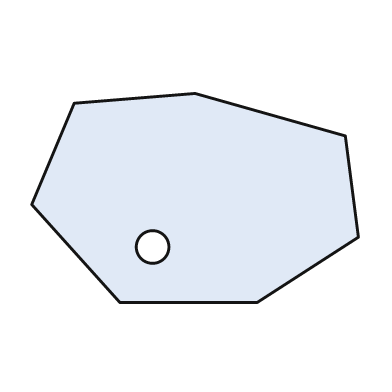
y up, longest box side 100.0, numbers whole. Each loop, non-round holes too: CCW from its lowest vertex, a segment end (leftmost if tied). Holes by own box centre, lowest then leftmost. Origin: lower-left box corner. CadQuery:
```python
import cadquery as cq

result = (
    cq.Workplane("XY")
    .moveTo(27.0, 0.0)
    .lineTo(69.0, 0.0)
    .lineTo(100.0, 20.0)
    .lineTo(96.0, 51.0)
    .lineTo(50.0, 64.0)
    .lineTo(13.0, 61.0)
    .lineTo(0.0, 30.0)
    .close()
    .moveTo(37.0, 17.0)
    .circle(5.0)
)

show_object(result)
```